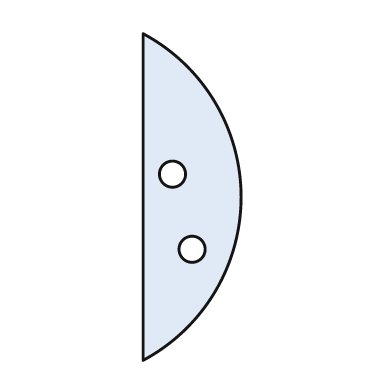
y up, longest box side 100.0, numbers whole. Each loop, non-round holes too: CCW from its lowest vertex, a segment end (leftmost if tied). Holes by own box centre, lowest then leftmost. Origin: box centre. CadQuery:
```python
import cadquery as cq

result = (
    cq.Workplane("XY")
    .moveTo(-15.0, -50.0)
    .threePointArc((15.0, 0.0), (-15.0, 50.0))
    .close()
    .moveTo(0.0, -16.0)
    .circle(4.0)
    .moveTo(-6.0, 7.0)
    .circle(4.0)
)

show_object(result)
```